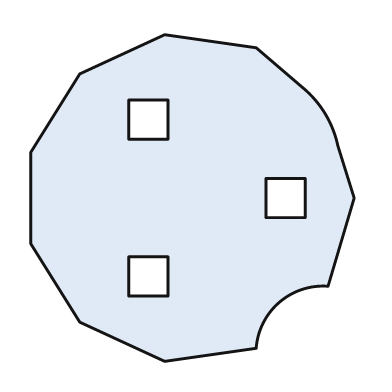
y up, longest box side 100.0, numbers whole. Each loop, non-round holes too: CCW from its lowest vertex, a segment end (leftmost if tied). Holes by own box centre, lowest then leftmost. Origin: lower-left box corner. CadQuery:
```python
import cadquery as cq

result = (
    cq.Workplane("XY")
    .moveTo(41.0, 0.0)
    .lineTo(69.0, 4.0)
    .threePointArc((76.0, 18.0), (91.0, 23.0))
    .lineTo(99.0, 50.0)
    .lineTo(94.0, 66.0)
    .threePointArc((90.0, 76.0), (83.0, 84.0))
    .lineTo(69.0, 96.0)
    .lineTo(41.0, 100.0)
    .lineTo(15.0, 88.0)
    .lineTo(0.0, 64.0)
    .lineTo(0.0, 36.0)
    .lineTo(15.0, 12.0)
    .close()
    .moveTo(30.0, 20.0)
    .lineTo(42.0, 20.0)
    .lineTo(42.0, 32.0)
    .lineTo(30.0, 32.0)
    .close()
    .moveTo(72.0, 44.0)
    .lineTo(84.0, 44.0)
    .lineTo(84.0, 56.0)
    .lineTo(72.0, 56.0)
    .close()
    .moveTo(30.0, 68.0)
    .lineTo(42.0, 68.0)
    .lineTo(42.0, 80.0)
    .lineTo(30.0, 80.0)
    .close()
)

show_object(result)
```